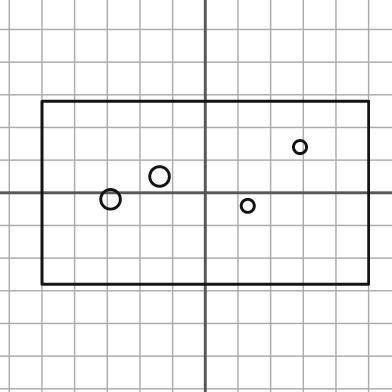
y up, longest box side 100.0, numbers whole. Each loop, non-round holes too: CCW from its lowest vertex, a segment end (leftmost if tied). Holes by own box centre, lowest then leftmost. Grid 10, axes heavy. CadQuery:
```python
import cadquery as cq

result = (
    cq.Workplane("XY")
    .moveTo(-50.0, -28.0)
    .lineTo(50.0, -28.0)
    .lineTo(50.0, 28.0)
    .lineTo(-50.0, 28.0)
    .close()
    .moveTo(13.0, -4.0)
    .circle(2.0)
    .moveTo(-29.0, -2.0)
    .circle(3.0)
    .moveTo(-14.0, 5.0)
    .circle(3.0)
    .moveTo(29.0, 14.0)
    .circle(2.0)
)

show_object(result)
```